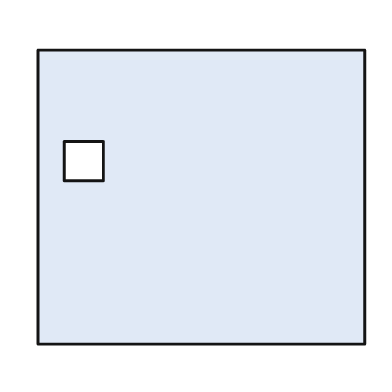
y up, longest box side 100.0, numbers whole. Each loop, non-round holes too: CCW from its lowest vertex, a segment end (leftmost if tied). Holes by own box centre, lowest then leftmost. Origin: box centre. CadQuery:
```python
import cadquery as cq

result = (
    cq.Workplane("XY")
    .moveTo(-50.0, -45.0)
    .lineTo(50.0, -45.0)
    .lineTo(50.0, 45.0)
    .lineTo(-50.0, 45.0)
    .close()
    .moveTo(-42.0, 5.0)
    .lineTo(-30.0, 5.0)
    .lineTo(-30.0, 17.0)
    .lineTo(-42.0, 17.0)
    .close()
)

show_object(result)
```